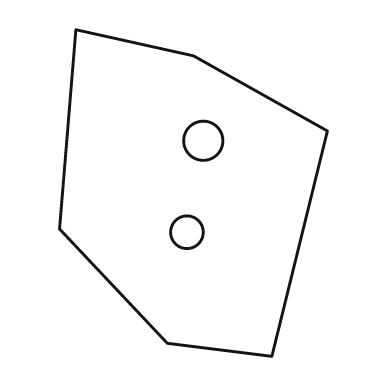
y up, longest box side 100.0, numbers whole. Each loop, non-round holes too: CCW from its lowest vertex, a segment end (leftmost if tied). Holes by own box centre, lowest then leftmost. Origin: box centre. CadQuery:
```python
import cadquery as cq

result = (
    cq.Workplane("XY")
    .moveTo(24.0, -50.0)
    .lineTo(41.0, 19.0)
    .lineTo(0.0, 42.0)
    .lineTo(-36.0, 50.0)
    .lineTo(-41.0, -11.0)
    .lineTo(-8.0, -46.0)
    .close()
    .moveTo(-2.0, -12.0)
    .circle(5.0)
    .moveTo(3.0, 16.0)
    .circle(6.0)
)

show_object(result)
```